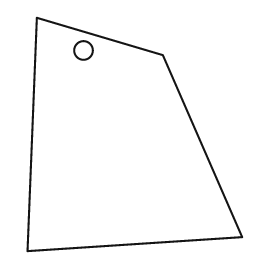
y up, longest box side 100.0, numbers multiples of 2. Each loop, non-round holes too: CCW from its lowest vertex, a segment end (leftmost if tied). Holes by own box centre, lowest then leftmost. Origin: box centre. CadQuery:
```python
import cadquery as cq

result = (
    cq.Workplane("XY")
    .moveTo(-46.0, -50.0)
    .lineTo(46.0, -44.0)
    .lineTo(12.0, 34.0)
    .lineTo(-42.0, 50.0)
    .close()
    .moveTo(-22.0, 36.0)
    .circle(4.0)
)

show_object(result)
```